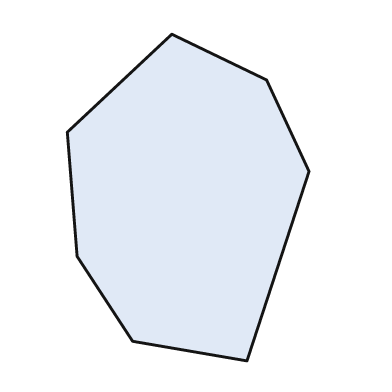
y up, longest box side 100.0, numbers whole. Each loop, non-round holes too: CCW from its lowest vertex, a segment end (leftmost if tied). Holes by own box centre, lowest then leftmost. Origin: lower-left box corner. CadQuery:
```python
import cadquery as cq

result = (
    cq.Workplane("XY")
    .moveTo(55.0, 0.0)
    .lineTo(74.0, 58.0)
    .lineTo(61.0, 86.0)
    .lineTo(32.0, 100.0)
    .lineTo(0.0, 70.0)
    .lineTo(3.0, 32.0)
    .lineTo(20.0, 6.0)
    .close()
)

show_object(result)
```